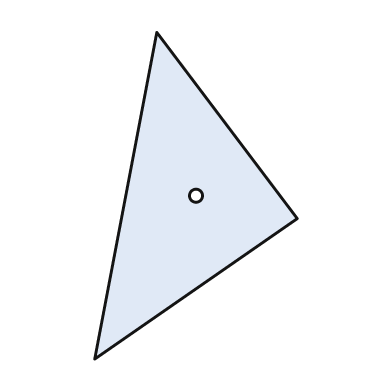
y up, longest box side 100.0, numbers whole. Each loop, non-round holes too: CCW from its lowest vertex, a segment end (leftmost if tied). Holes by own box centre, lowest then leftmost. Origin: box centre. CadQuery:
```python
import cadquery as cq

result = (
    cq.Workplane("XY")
    .moveTo(-31.0, -50.0)
    .lineTo(31.0, -7.0)
    .lineTo(-12.0, 50.0)
    .close()
    .moveTo(0.0, 0.0)
    .circle(2.0)
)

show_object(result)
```